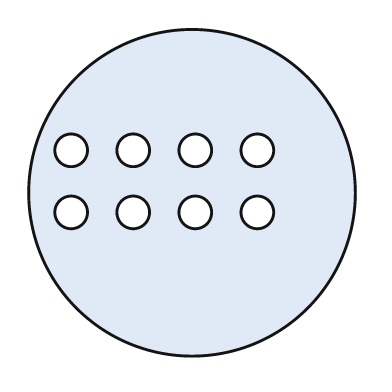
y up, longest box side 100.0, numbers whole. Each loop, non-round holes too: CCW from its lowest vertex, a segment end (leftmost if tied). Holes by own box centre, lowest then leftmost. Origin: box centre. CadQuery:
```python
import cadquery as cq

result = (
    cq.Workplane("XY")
    .moveTo(0.0, 0.0)
    .circle(50.0)
    .moveTo(-37.0, -6.0)
    .circle(5.0)
    .moveTo(-18.0, -6.0)
    .circle(5.0)
    .moveTo(1.0, -6.0)
    .circle(5.0)
    .moveTo(20.0, -6.0)
    .circle(5.0)
    .moveTo(-37.0, 13.0)
    .circle(5.0)
    .moveTo(-18.0, 13.0)
    .circle(5.0)
    .moveTo(1.0, 13.0)
    .circle(5.0)
    .moveTo(20.0, 13.0)
    .circle(5.0)
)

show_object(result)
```